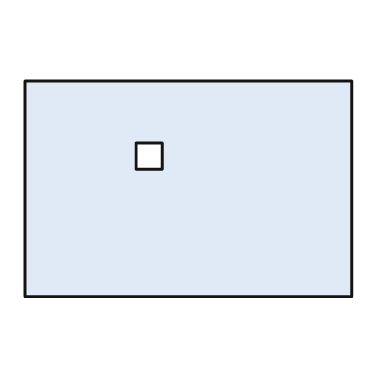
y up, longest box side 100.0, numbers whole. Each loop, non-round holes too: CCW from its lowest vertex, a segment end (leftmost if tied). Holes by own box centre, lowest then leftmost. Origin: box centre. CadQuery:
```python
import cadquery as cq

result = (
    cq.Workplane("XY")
    .moveTo(-50.0, -33.0)
    .lineTo(50.0, -33.0)
    .lineTo(50.0, 33.0)
    .lineTo(-50.0, 33.0)
    .close()
    .moveTo(-16.0, 6.0)
    .lineTo(-8.0, 6.0)
    .lineTo(-8.0, 14.0)
    .lineTo(-16.0, 14.0)
    .close()
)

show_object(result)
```